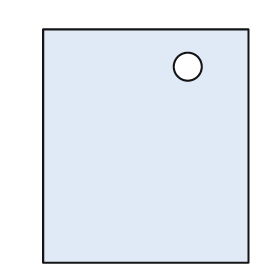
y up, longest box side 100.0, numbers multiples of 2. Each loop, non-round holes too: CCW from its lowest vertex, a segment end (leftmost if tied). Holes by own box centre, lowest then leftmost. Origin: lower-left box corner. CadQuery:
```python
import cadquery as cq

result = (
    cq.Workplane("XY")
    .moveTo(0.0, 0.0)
    .lineTo(88.0, 0.0)
    .lineTo(88.0, 100.0)
    .lineTo(0.0, 100.0)
    .close()
    .moveTo(62.0, 84.0)
    .circle(6.0)
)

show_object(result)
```